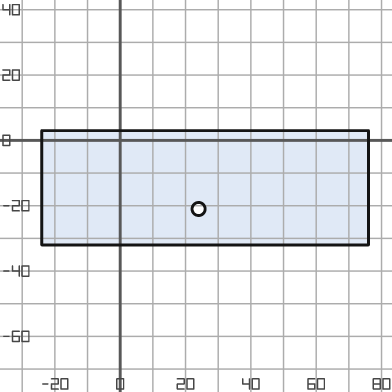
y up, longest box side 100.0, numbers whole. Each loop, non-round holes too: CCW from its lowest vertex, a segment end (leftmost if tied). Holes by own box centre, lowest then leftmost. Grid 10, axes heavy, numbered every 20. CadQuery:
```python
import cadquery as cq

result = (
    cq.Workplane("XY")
    .moveTo(-24.0, -32.0)
    .lineTo(76.0, -32.0)
    .lineTo(76.0, 3.0)
    .lineTo(-24.0, 3.0)
    .close()
    .moveTo(24.0, -21.0)
    .circle(2.0)
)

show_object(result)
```